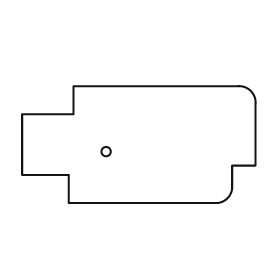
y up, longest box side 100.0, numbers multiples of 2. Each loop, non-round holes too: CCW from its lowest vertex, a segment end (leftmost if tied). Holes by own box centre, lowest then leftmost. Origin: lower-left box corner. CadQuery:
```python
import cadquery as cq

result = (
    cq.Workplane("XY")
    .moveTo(20.0, 0.0)
    .lineTo(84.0, 0.0)
    .threePointArc((88.0, 2.0), (90.0, 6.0))
    .lineTo(90.0, 16.0)
    .lineTo(100.0, 16.0)
    .lineTo(100.0, 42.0)
    .threePointArc((98.0, 48.0), (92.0, 50.0))
    .lineTo(22.0, 50.0)
    .lineTo(22.0, 38.0)
    .lineTo(0.0, 38.0)
    .lineTo(0.0, 12.0)
    .lineTo(20.0, 12.0)
    .close()
    .moveTo(36.0, 22.0)
    .circle(2.0)
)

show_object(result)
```